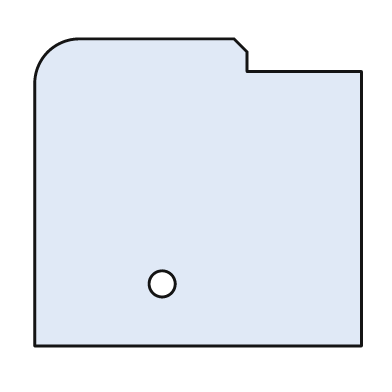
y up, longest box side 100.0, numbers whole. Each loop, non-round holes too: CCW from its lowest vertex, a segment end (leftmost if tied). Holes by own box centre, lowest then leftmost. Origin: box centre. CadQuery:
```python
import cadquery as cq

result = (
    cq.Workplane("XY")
    .moveTo(-50.0, -47.0)
    .lineTo(50.0, -47.0)
    .lineTo(50.0, 37.0)
    .lineTo(15.0, 37.0)
    .lineTo(15.0, 43.0)
    .lineTo(11.0, 47.0)
    .lineTo(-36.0, 47.0)
    .threePointArc((-46.0, 43.0), (-50.0, 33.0))
    .close()
    .moveTo(-11.0, -28.0)
    .circle(4.0)
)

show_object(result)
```